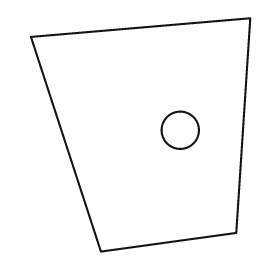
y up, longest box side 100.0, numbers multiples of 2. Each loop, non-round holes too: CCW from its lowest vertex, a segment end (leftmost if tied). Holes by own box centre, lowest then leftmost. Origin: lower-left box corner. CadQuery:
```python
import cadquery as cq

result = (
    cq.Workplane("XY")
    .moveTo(30.0, 0.0)
    .lineTo(88.0, 8.0)
    .lineTo(94.0, 100.0)
    .lineTo(0.0, 92.0)
    .close()
    .moveTo(64.0, 52.0)
    .circle(8.0)
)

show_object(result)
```